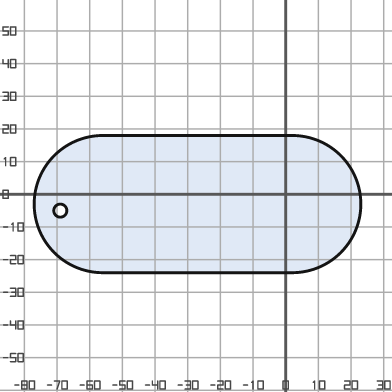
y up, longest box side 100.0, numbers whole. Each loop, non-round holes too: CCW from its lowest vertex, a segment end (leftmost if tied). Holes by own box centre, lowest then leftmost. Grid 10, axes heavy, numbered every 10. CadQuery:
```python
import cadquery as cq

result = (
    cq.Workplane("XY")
    .moveTo(-56.0, -24.0)
    .lineTo(2.0, -24.0)
    .threePointArc((23.0, -3.0), (2.0, 18.0))
    .lineTo(-56.0, 18.0)
    .threePointArc((-77.0, -3.0), (-56.0, -24.0))
    .close()
    .moveTo(-69.0, -5.0)
    .circle(2.0)
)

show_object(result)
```